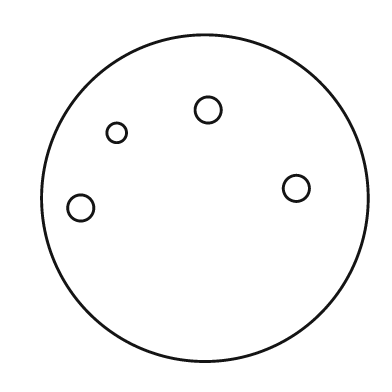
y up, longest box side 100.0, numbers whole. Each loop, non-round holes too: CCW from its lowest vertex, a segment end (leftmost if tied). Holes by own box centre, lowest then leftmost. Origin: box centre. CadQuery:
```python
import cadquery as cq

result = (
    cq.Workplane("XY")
    .moveTo(0.0, 0.0)
    .circle(50.0)
    .moveTo(-38.0, -3.0)
    .circle(4.0)
    .moveTo(28.0, 3.0)
    .circle(4.0)
    .moveTo(-27.0, 20.0)
    .circle(3.0)
    .moveTo(1.0, 27.0)
    .circle(4.0)
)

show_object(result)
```